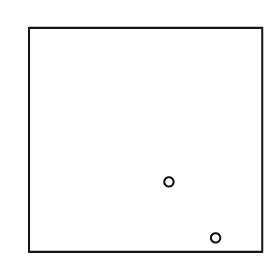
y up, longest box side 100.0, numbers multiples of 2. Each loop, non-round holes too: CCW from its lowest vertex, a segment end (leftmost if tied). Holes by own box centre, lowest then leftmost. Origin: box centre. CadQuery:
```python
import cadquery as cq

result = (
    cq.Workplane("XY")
    .moveTo(-50.0, -48.0)
    .lineTo(50.0, -48.0)
    .lineTo(50.0, 48.0)
    .lineTo(-50.0, 48.0)
    .close()
    .moveTo(30.0, -42.0)
    .circle(2.0)
    .moveTo(10.0, -18.0)
    .circle(2.0)
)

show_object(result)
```